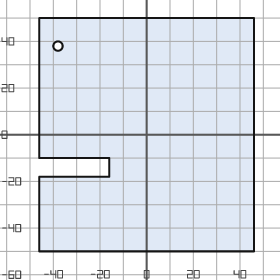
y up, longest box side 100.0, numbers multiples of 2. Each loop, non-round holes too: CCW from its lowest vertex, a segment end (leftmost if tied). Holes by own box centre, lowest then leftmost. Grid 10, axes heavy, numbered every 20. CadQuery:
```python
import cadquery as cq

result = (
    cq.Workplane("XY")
    .moveTo(-46.0, -50.0)
    .lineTo(46.0, -50.0)
    .lineTo(46.0, 50.0)
    .lineTo(-46.0, 50.0)
    .lineTo(-46.0, -10.0)
    .lineTo(-16.0, -10.0)
    .lineTo(-16.0, -18.0)
    .lineTo(-46.0, -18.0)
    .close()
    .moveTo(-38.0, 38.0)
    .circle(2.0)
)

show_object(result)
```